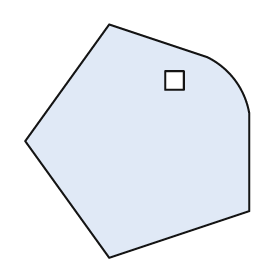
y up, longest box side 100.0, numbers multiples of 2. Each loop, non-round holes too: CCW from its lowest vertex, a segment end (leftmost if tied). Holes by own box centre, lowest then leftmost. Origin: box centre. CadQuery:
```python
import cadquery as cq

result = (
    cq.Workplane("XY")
    .moveTo(-12.0, -50.0)
    .lineTo(48.0, -30.0)
    .lineTo(48.0, 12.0)
    .threePointArc((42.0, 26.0), (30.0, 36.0))
    .lineTo(-12.0, 50.0)
    .lineTo(-48.0, 0.0)
    .close()
    .moveTo(12.0, 22.0)
    .lineTo(20.0, 22.0)
    .lineTo(20.0, 30.0)
    .lineTo(12.0, 30.0)
    .close()
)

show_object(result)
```